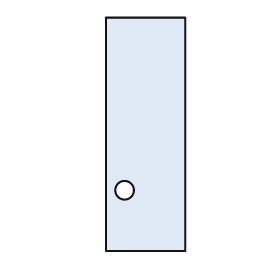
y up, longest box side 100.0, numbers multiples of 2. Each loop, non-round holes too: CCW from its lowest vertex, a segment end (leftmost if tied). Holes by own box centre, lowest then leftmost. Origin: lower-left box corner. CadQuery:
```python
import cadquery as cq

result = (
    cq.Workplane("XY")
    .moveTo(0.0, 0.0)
    .lineTo(34.0, 0.0)
    .lineTo(34.0, 100.0)
    .lineTo(0.0, 100.0)
    .close()
    .moveTo(8.0, 26.0)
    .circle(4.0)
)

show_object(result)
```